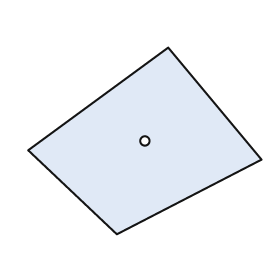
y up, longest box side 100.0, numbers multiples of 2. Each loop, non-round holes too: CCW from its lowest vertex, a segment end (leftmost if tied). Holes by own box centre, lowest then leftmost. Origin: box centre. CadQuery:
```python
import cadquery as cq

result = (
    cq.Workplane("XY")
    .moveTo(-12.0, -40.0)
    .lineTo(50.0, -8.0)
    .lineTo(10.0, 40.0)
    .lineTo(-50.0, -4.0)
    .close()
    .moveTo(0.0, 0.0)
    .circle(2.0)
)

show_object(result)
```